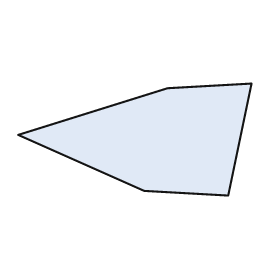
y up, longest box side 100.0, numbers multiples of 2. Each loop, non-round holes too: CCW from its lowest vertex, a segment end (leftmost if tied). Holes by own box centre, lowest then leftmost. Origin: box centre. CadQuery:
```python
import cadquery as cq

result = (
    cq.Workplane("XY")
    .moveTo(40.0, -24.0)
    .lineTo(50.0, 24.0)
    .lineTo(14.0, 22.0)
    .lineTo(-50.0, 2.0)
    .lineTo(4.0, -22.0)
    .close()
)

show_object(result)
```